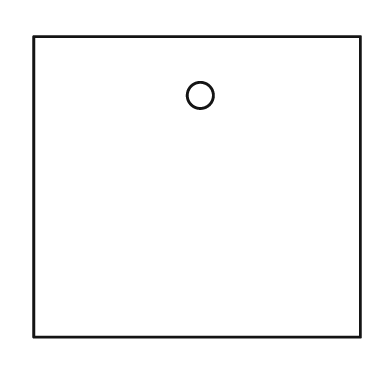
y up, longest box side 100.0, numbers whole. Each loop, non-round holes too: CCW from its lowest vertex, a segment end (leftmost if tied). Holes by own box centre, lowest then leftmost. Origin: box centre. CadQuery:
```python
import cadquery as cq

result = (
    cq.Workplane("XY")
    .moveTo(-50.0, -46.0)
    .lineTo(50.0, -46.0)
    .lineTo(50.0, 46.0)
    .lineTo(-50.0, 46.0)
    .close()
    .moveTo(1.0, 28.0)
    .circle(4.0)
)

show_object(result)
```